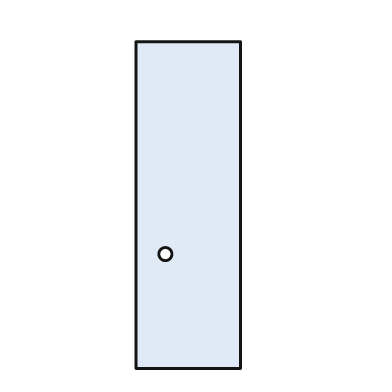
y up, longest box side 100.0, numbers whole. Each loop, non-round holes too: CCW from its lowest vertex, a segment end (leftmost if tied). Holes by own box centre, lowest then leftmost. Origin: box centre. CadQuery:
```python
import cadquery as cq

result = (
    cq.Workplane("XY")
    .moveTo(-16.0, -50.0)
    .lineTo(16.0, -50.0)
    .lineTo(16.0, 50.0)
    .lineTo(-16.0, 50.0)
    .close()
    .moveTo(-7.0, -15.0)
    .circle(2.0)
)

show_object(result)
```